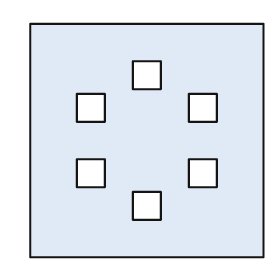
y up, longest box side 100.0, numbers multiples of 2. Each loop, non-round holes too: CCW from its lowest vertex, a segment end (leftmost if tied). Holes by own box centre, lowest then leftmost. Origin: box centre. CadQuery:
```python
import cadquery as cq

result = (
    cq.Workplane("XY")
    .moveTo(-50.0, -50.0)
    .lineTo(50.0, -50.0)
    .lineTo(50.0, 50.0)
    .lineTo(-50.0, 50.0)
    .close()
    .moveTo(-6.0, -34.0)
    .lineTo(6.0, -34.0)
    .lineTo(6.0, -22.0)
    .lineTo(-6.0, -22.0)
    .close()
    .moveTo(-30.0, -20.0)
    .lineTo(-18.0, -20.0)
    .lineTo(-18.0, -8.0)
    .lineTo(-30.0, -8.0)
    .close()
    .moveTo(18.0, -20.0)
    .lineTo(30.0, -20.0)
    .lineTo(30.0, -8.0)
    .lineTo(18.0, -8.0)
    .close()
    .moveTo(-30.0, 8.0)
    .lineTo(-18.0, 8.0)
    .lineTo(-18.0, 20.0)
    .lineTo(-30.0, 20.0)
    .close()
    .moveTo(18.0, 8.0)
    .lineTo(30.0, 8.0)
    .lineTo(30.0, 20.0)
    .lineTo(18.0, 20.0)
    .close()
    .moveTo(-6.0, 22.0)
    .lineTo(6.0, 22.0)
    .lineTo(6.0, 34.0)
    .lineTo(-6.0, 34.0)
    .close()
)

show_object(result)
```